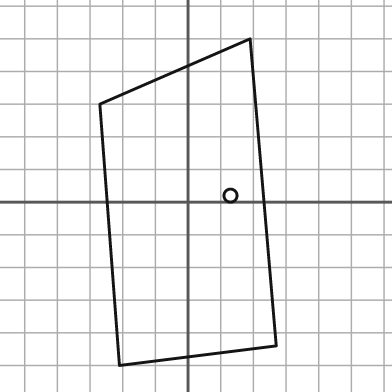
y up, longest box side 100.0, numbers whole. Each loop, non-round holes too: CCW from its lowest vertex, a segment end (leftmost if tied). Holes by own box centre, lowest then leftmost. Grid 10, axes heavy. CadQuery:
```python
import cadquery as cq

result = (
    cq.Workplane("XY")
    .moveTo(-21.0, -50.0)
    .lineTo(27.0, -44.0)
    .lineTo(19.0, 50.0)
    .lineTo(-27.0, 30.0)
    .close()
    .moveTo(13.0, 2.0)
    .circle(2.0)
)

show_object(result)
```